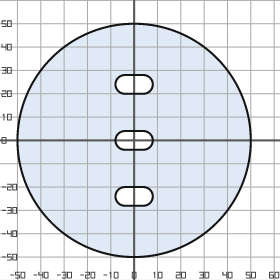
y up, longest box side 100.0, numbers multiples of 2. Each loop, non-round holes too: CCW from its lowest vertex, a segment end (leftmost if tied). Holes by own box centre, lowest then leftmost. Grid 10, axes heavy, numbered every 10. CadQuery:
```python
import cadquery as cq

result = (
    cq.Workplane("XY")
    .moveTo(0.0, 0.0)
    .circle(50.0)
    .moveTo(-4.0, -28.0)
    .lineTo(4.0, -28.0)
    .threePointArc((8.0, -24.0), (4.0, -20.0))
    .lineTo(-4.0, -20.0)
    .threePointArc((-8.0, -24.0), (-4.0, -28.0))
    .close()
    .moveTo(-4.0, -4.0)
    .lineTo(4.0, -4.0)
    .threePointArc((8.0, 0.0), (4.0, 4.0))
    .lineTo(-4.0, 4.0)
    .threePointArc((-8.0, 0.0), (-4.0, -4.0))
    .close()
    .moveTo(-4.0, 20.0)
    .lineTo(4.0, 20.0)
    .threePointArc((8.0, 24.0), (4.0, 28.0))
    .lineTo(-4.0, 28.0)
    .threePointArc((-8.0, 24.0), (-4.0, 20.0))
    .close()
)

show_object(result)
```